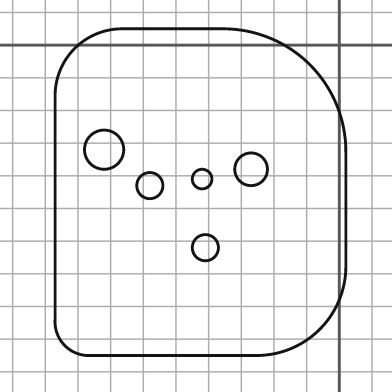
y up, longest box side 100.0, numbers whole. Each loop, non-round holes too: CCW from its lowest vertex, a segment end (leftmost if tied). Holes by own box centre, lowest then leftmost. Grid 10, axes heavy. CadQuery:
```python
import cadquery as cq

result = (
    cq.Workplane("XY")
    .moveTo(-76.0, -95.0)
    .lineTo(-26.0, -95.0)
    .threePointArc((-6.0, -87.0), (2.0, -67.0))
    .lineTo(2.0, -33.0)
    .threePointArc((-9.0, -6.0), (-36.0, 5.0))
    .lineTo(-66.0, 5.0)
    .threePointArc((-81.0, -1.0), (-87.0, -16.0))
    .lineTo(-87.0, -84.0)
    .threePointArc((-84.0, -92.0), (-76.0, -95.0))
    .close()
    .moveTo(-41.0, -62.0)
    .circle(4.0)
    .moveTo(-58.0, -43.0)
    .circle(4.0)
    .moveTo(-42.0, -41.0)
    .circle(3.0)
    .moveTo(-27.0, -38.0)
    .circle(5.0)
    .moveTo(-72.0, -32.0)
    .circle(6.0)
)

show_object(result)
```